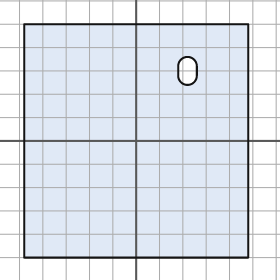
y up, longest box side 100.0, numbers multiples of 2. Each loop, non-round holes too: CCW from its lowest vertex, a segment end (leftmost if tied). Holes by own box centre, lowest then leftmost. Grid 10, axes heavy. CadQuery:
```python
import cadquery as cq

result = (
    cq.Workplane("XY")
    .moveTo(-48.0, -50.0)
    .lineTo(48.0, -50.0)
    .lineTo(48.0, 50.0)
    .lineTo(-48.0, 50.0)
    .close()
    .moveTo(18.0, 28.0)
    .threePointArc((22.0, 24.0), (26.0, 28.0))
    .lineTo(26.0, 32.0)
    .threePointArc((22.0, 36.0), (18.0, 32.0))
    .close()
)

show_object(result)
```